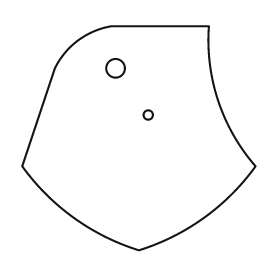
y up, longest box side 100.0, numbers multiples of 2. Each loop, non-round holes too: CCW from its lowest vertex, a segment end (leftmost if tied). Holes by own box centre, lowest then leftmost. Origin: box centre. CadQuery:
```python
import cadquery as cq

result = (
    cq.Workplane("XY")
    .moveTo(0.0, -48.0)
    .threePointArc((28.0, -34.0), (50.0, -12.0))
    .threePointArc((34.0, 16.0), (30.0, 48.0))
    .lineTo(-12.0, 48.0)
    .threePointArc((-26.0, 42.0), (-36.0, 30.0))
    .lineTo(-50.0, -12.0)
    .threePointArc((-28.0, -34.0), (0.0, -48.0))
    .close()
    .moveTo(4.0, 10.0)
    .circle(2.0)
    .moveTo(-10.0, 30.0)
    .circle(4.0)
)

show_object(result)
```